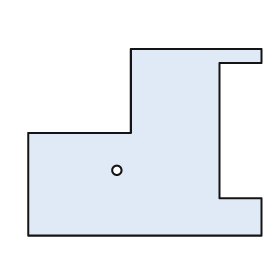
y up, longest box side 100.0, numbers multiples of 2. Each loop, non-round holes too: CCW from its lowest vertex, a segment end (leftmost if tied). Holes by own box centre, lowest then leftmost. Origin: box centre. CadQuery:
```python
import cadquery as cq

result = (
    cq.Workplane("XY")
    .moveTo(-50.0, -40.0)
    .lineTo(50.0, -40.0)
    .lineTo(50.0, -24.0)
    .lineTo(32.0, -24.0)
    .lineTo(32.0, 34.0)
    .lineTo(50.0, 34.0)
    .lineTo(50.0, 40.0)
    .lineTo(-6.0, 40.0)
    .lineTo(-6.0, 4.0)
    .lineTo(-50.0, 4.0)
    .close()
    .moveTo(-12.0, -12.0)
    .circle(2.0)
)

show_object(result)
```